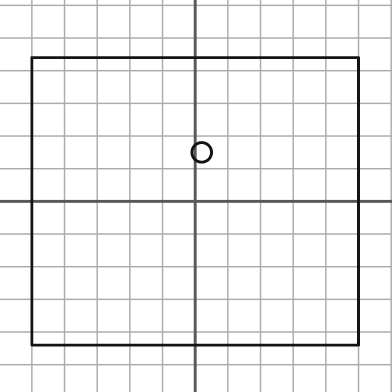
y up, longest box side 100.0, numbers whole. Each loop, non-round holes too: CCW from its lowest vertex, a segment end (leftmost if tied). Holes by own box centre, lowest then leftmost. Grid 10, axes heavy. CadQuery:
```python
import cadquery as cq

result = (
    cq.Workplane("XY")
    .moveTo(-50.0, -44.0)
    .lineTo(50.0, -44.0)
    .lineTo(50.0, 44.0)
    .lineTo(-50.0, 44.0)
    .close()
    .moveTo(2.0, 15.0)
    .circle(3.0)
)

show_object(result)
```